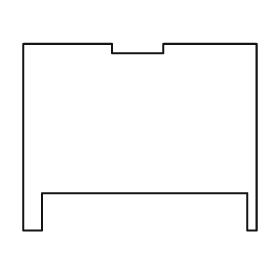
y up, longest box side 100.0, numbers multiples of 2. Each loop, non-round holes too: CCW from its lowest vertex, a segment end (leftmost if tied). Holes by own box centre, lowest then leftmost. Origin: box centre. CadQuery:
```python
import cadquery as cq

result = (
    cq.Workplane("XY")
    .moveTo(-50.0, -40.0)
    .lineTo(-42.0, -40.0)
    .lineTo(-42.0, -24.0)
    .lineTo(46.0, -24.0)
    .lineTo(46.0, -40.0)
    .lineTo(50.0, -40.0)
    .lineTo(50.0, 40.0)
    .lineTo(10.0, 40.0)
    .lineTo(10.0, 36.0)
    .lineTo(-12.0, 36.0)
    .lineTo(-12.0, 40.0)
    .lineTo(-50.0, 40.0)
    .close()
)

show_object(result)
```